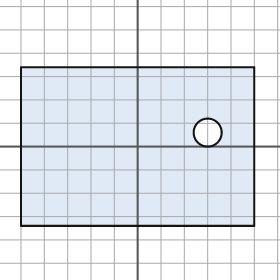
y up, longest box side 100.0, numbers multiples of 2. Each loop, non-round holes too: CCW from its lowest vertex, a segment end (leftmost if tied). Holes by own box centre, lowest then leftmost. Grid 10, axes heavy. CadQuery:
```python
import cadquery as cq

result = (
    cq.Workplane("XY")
    .moveTo(-50.0, -34.0)
    .lineTo(50.0, -34.0)
    .lineTo(50.0, 34.0)
    .lineTo(-50.0, 34.0)
    .close()
    .moveTo(30.0, 6.0)
    .circle(6.0)
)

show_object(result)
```